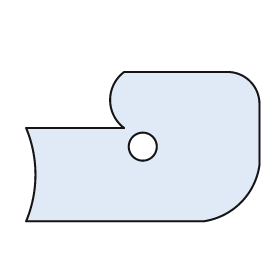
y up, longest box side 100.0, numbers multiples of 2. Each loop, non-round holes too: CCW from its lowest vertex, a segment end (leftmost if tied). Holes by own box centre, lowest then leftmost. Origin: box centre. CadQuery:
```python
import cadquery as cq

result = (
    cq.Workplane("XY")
    .moveTo(-50.0, -32.0)
    .lineTo(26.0, -32.0)
    .threePointArc((42.0, -24.0), (50.0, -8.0))
    .lineTo(50.0, 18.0)
    .threePointArc((46.0, 28.0), (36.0, 32.0))
    .lineTo(-8.0, 32.0)
    .threePointArc((-14.0, 20.0), (-8.0, 8.0))
    .lineTo(-50.0, 8.0)
    .threePointArc((-46.0, -12.0), (-50.0, -32.0))
    .close()
    .moveTo(0.0, 0.0)
    .circle(6.0)
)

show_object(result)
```